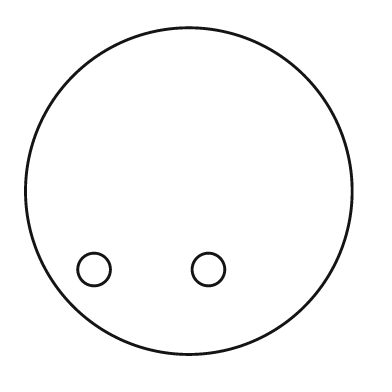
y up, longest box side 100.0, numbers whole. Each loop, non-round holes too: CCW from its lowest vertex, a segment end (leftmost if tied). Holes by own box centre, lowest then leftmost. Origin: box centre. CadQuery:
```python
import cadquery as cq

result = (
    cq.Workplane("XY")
    .moveTo(0.0, 0.0)
    .circle(50.0)
    .moveTo(-29.0, -24.0)
    .circle(5.0)
    .moveTo(6.0, -24.0)
    .circle(5.0)
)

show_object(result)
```